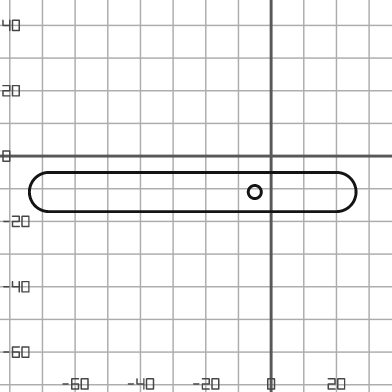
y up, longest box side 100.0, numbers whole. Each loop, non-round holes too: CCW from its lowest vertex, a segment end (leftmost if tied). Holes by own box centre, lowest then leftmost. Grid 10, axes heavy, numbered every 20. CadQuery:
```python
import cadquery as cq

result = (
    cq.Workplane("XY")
    .moveTo(-68.0, -17.0)
    .lineTo(20.0, -17.0)
    .threePointArc((26.0, -11.0), (20.0, -5.0))
    .lineTo(-68.0, -5.0)
    .threePointArc((-74.0, -11.0), (-68.0, -17.0))
    .close()
    .moveTo(-5.0, -11.0)
    .circle(2.0)
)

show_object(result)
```